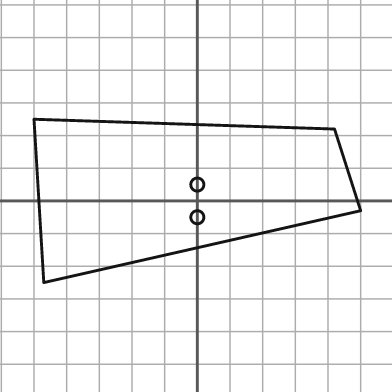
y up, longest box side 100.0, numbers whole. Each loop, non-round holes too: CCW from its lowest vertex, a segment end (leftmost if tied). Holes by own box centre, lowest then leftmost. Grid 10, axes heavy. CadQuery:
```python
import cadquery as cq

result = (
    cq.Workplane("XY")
    .moveTo(-47.0, -25.0)
    .lineTo(50.0, -3.0)
    .lineTo(42.0, 22.0)
    .lineTo(-50.0, 25.0)
    .close()
    .moveTo(0.0, -5.0)
    .circle(2.0)
    .moveTo(0.0, 5.0)
    .circle(2.0)
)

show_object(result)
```